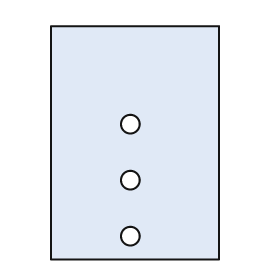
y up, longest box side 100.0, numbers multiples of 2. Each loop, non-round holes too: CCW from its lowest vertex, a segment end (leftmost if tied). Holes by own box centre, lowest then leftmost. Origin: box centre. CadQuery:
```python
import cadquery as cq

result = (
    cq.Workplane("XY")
    .moveTo(-36.0, -50.0)
    .lineTo(36.0, -50.0)
    .lineTo(36.0, 50.0)
    .lineTo(-36.0, 50.0)
    .close()
    .moveTo(-2.0, -40.0)
    .circle(4.0)
    .moveTo(-2.0, -16.0)
    .circle(4.0)
    .moveTo(-2.0, 8.0)
    .circle(4.0)
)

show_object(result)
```